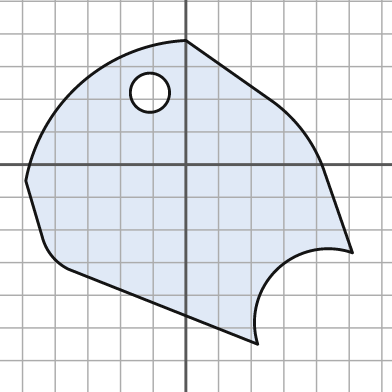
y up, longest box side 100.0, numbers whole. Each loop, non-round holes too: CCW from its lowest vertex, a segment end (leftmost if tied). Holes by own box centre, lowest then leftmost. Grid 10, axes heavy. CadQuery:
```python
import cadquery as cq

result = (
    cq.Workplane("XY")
    .moveTo(22.0, -55.0)
    .threePointArc((28.0, -32.0), (51.0, -27.0))
    .lineTo(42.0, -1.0)
    .threePointArc((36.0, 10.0), (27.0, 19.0))
    .lineTo(0.0, 38.0)
    .threePointArc((-32.0, 25.0), (-49.0, -5.0))
    .lineTo(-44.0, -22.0)
    .threePointArc((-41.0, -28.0), (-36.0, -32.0))
    .close()
    .moveTo(-11.0, 22.0)
    .circle(6.0)
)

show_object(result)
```